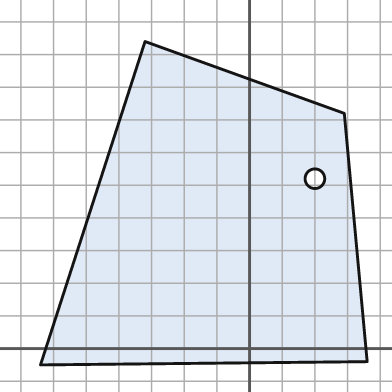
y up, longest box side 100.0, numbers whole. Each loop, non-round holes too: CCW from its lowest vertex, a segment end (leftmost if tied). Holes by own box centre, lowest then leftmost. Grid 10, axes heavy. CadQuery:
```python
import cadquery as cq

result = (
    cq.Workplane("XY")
    .moveTo(-64.0, -5.0)
    .lineTo(36.0, -4.0)
    .lineTo(29.0, 72.0)
    .lineTo(-32.0, 94.0)
    .close()
    .moveTo(20.0, 52.0)
    .circle(3.0)
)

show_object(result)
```